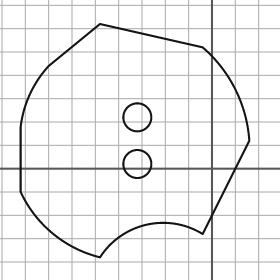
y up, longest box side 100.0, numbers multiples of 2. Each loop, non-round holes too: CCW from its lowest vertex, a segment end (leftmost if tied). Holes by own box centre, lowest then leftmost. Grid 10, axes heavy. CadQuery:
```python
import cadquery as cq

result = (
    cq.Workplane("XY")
    .moveTo(-48.0, -38.0)
    .threePointArc((-28.0, -24.0), (-4.0, -28.0))
    .lineTo(16.0, 12.0)
    .threePointArc((10.0, 34.0), (-4.0, 52.0))
    .lineTo(-48.0, 62.0)
    .lineTo(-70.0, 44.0)
    .threePointArc((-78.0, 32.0), (-82.0, 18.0))
    .lineTo(-82.0, -10.0)
    .threePointArc((-68.0, -28.0), (-48.0, -38.0))
    .close()
    .moveTo(-32.0, 2.0)
    .circle(6.0)
    .moveTo(-32.0, 22.0)
    .circle(6.0)
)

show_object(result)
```